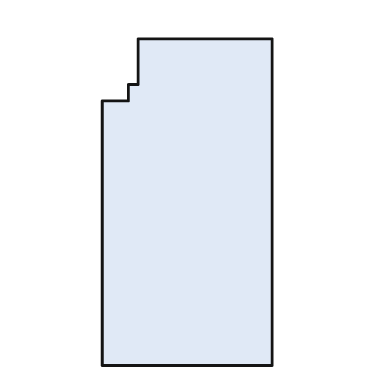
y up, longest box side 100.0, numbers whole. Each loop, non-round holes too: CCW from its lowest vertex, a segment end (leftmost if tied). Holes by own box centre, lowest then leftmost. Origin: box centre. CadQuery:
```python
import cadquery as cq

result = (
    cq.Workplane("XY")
    .moveTo(-26.0, -50.0)
    .lineTo(26.0, -50.0)
    .lineTo(26.0, 50.0)
    .lineTo(-15.0, 50.0)
    .lineTo(-15.0, 36.0)
    .lineTo(-18.0, 36.0)
    .lineTo(-18.0, 31.0)
    .lineTo(-26.0, 31.0)
    .close()
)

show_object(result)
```